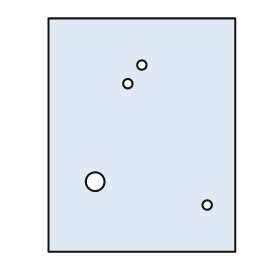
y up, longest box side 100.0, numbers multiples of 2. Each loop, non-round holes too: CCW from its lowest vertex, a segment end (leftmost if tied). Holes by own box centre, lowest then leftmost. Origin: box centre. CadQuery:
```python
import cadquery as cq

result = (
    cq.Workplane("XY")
    .moveTo(-40.0, -50.0)
    .lineTo(40.0, -50.0)
    .lineTo(40.0, 50.0)
    .lineTo(-40.0, 50.0)
    .close()
    .moveTo(28.0, -30.0)
    .circle(2.0)
    .moveTo(-20.0, -20.0)
    .circle(4.0)
    .moveTo(-6.0, 22.0)
    .circle(2.0)
    .moveTo(0.0, 30.0)
    .circle(2.0)
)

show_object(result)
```